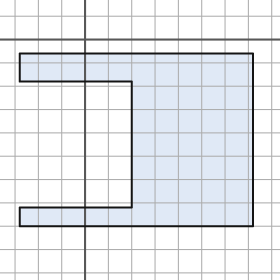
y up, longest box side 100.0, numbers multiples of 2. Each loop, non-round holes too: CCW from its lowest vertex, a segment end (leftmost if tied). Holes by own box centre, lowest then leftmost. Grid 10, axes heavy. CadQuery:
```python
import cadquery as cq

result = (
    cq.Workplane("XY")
    .moveTo(-28.0, -80.0)
    .lineTo(72.0, -80.0)
    .lineTo(72.0, -6.0)
    .lineTo(-28.0, -6.0)
    .lineTo(-28.0, -18.0)
    .lineTo(20.0, -18.0)
    .lineTo(20.0, -72.0)
    .lineTo(-28.0, -72.0)
    .close()
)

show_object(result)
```